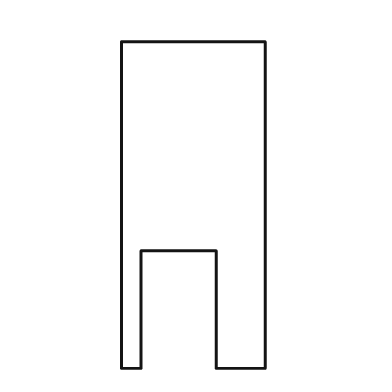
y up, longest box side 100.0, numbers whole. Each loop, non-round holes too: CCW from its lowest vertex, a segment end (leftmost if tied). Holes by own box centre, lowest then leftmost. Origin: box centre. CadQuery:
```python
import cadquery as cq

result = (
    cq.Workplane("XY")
    .moveTo(-22.0, -50.0)
    .lineTo(-16.0, -50.0)
    .lineTo(-16.0, -14.0)
    .lineTo(7.0, -14.0)
    .lineTo(7.0, -50.0)
    .lineTo(22.0, -50.0)
    .lineTo(22.0, 50.0)
    .lineTo(-22.0, 50.0)
    .close()
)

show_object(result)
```